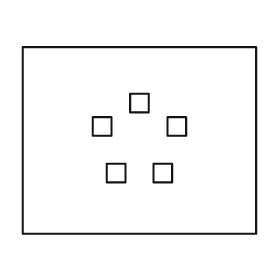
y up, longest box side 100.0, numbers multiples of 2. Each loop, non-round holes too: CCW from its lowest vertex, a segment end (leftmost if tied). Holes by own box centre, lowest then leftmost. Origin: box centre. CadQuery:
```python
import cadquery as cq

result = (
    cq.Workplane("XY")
    .moveTo(-50.0, -40.0)
    .lineTo(50.0, -40.0)
    .lineTo(50.0, 40.0)
    .lineTo(-50.0, 40.0)
    .close()
    .moveTo(-14.0, -18.0)
    .lineTo(-6.0, -18.0)
    .lineTo(-6.0, -10.0)
    .lineTo(-14.0, -10.0)
    .close()
    .moveTo(6.0, -18.0)
    .lineTo(14.0, -18.0)
    .lineTo(14.0, -10.0)
    .lineTo(6.0, -10.0)
    .close()
    .moveTo(-20.0, 2.0)
    .lineTo(-12.0, 2.0)
    .lineTo(-12.0, 10.0)
    .lineTo(-20.0, 10.0)
    .close()
    .moveTo(12.0, 2.0)
    .lineTo(20.0, 2.0)
    .lineTo(20.0, 10.0)
    .lineTo(12.0, 10.0)
    .close()
    .moveTo(-4.0, 12.0)
    .lineTo(4.0, 12.0)
    .lineTo(4.0, 20.0)
    .lineTo(-4.0, 20.0)
    .close()
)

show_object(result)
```